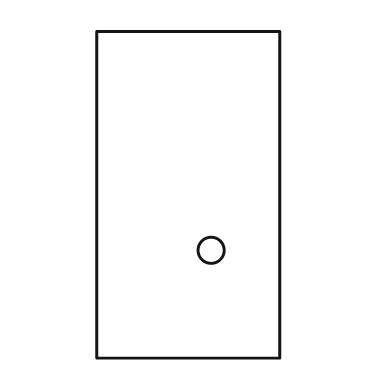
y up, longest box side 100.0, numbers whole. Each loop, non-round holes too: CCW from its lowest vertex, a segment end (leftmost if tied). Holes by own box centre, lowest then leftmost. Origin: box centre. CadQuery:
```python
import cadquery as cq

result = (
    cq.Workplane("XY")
    .moveTo(-28.0, -50.0)
    .lineTo(28.0, -50.0)
    .lineTo(28.0, 50.0)
    .lineTo(-28.0, 50.0)
    .close()
    .moveTo(7.0, -17.0)
    .circle(4.0)
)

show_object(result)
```